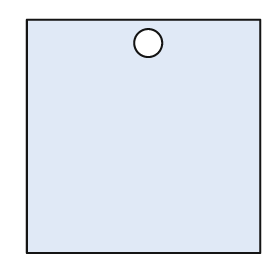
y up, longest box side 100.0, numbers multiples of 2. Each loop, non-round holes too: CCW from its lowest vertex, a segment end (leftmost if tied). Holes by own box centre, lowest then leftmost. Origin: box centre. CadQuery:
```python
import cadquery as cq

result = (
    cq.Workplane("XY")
    .moveTo(-50.0, -50.0)
    .lineTo(50.0, -50.0)
    .lineTo(50.0, 50.0)
    .lineTo(-50.0, 50.0)
    .close()
    .moveTo(2.0, 40.0)
    .circle(6.0)
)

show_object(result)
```